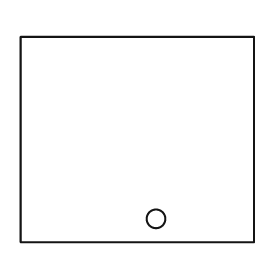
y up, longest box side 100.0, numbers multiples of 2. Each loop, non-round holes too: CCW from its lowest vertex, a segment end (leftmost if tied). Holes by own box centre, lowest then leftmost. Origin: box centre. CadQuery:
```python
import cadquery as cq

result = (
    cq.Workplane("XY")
    .moveTo(-50.0, -44.0)
    .lineTo(50.0, -44.0)
    .lineTo(50.0, 44.0)
    .lineTo(-50.0, 44.0)
    .close()
    .moveTo(8.0, -34.0)
    .circle(4.0)
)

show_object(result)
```